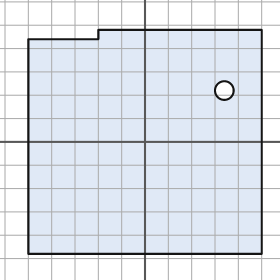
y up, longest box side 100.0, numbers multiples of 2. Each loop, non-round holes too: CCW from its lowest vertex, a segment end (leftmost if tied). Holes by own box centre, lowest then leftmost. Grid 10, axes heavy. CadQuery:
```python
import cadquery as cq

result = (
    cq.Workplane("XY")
    .moveTo(-50.0, -48.0)
    .lineTo(50.0, -48.0)
    .lineTo(50.0, 48.0)
    .lineTo(-20.0, 48.0)
    .lineTo(-20.0, 44.0)
    .lineTo(-50.0, 44.0)
    .close()
    .moveTo(34.0, 22.0)
    .circle(4.0)
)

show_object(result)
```